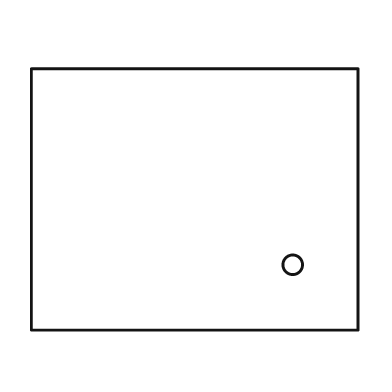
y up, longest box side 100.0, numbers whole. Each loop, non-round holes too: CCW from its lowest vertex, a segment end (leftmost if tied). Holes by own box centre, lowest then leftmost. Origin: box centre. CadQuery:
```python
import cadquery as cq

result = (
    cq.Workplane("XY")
    .moveTo(-50.0, -40.0)
    .lineTo(50.0, -40.0)
    .lineTo(50.0, 40.0)
    .lineTo(-50.0, 40.0)
    .close()
    .moveTo(30.0, -20.0)
    .circle(3.0)
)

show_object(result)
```